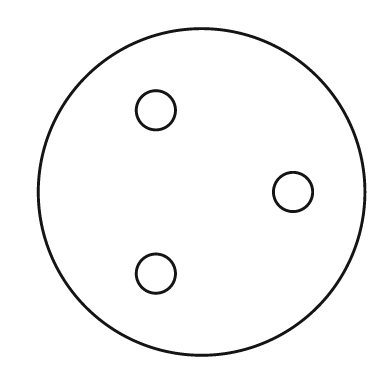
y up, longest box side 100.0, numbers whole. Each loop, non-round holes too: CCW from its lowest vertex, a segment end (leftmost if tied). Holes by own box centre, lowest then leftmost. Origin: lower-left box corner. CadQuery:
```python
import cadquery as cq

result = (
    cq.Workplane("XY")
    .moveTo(50.0, 50.0)
    .circle(50.0)
    .moveTo(36.0, 25.0)
    .circle(6.0)
    .moveTo(78.0, 50.0)
    .circle(6.0)
    .moveTo(36.0, 75.0)
    .circle(6.0)
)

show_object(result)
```